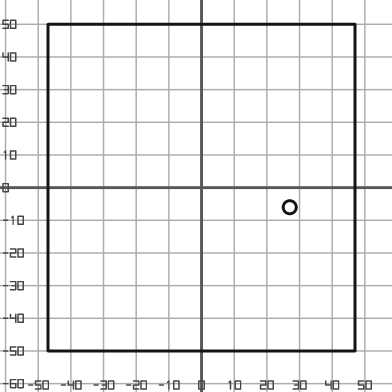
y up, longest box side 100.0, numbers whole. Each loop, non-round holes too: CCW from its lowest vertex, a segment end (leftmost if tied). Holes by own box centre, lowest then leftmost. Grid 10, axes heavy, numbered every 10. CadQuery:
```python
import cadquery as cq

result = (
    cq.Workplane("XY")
    .moveTo(-47.0, -50.0)
    .lineTo(47.0, -50.0)
    .lineTo(47.0, 50.0)
    .lineTo(-47.0, 50.0)
    .close()
    .moveTo(27.0, -6.0)
    .circle(2.0)
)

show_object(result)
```